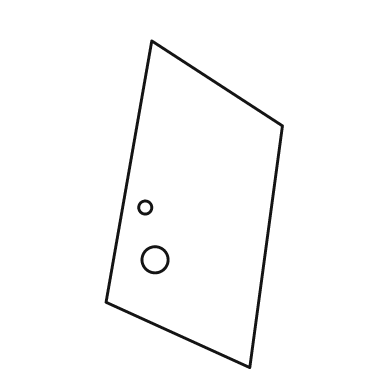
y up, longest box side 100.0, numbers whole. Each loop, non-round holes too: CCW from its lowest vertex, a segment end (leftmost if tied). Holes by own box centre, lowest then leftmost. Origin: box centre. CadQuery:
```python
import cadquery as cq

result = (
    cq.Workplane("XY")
    .moveTo(17.0, -50.0)
    .lineTo(27.0, 24.0)
    .lineTo(-13.0, 50.0)
    .lineTo(-27.0, -30.0)
    .close()
    .moveTo(-12.0, -17.0)
    .circle(4.0)
    .moveTo(-15.0, -1.0)
    .circle(2.0)
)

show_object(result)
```